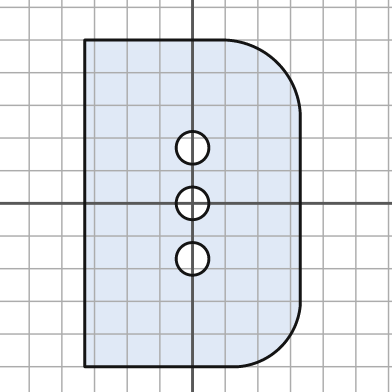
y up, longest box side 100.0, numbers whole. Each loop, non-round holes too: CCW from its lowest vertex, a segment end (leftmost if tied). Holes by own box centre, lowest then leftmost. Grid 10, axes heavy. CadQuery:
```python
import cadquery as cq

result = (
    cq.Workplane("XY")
    .moveTo(-33.0, -50.0)
    .lineTo(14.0, -50.0)
    .threePointArc((27.0, -44.0), (33.0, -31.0))
    .lineTo(33.0, 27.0)
    .threePointArc((26.0, 43.0), (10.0, 50.0))
    .lineTo(-33.0, 50.0)
    .close()
    .moveTo(0.0, -17.0)
    .circle(5.0)
    .moveTo(0.0, 0.0)
    .circle(5.0)
    .moveTo(0.0, 17.0)
    .circle(5.0)
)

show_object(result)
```